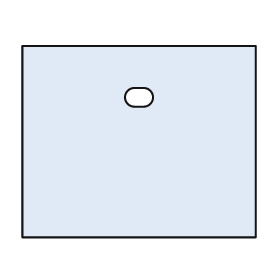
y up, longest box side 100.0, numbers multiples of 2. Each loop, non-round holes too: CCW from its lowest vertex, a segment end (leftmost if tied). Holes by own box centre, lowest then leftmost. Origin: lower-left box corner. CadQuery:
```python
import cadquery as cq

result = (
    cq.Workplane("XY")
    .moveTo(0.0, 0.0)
    .lineTo(100.0, 0.0)
    .lineTo(100.0, 82.0)
    .lineTo(0.0, 82.0)
    .close()
    .moveTo(48.0, 56.0)
    .lineTo(52.0, 56.0)
    .threePointArc((56.0, 60.0), (52.0, 64.0))
    .lineTo(48.0, 64.0)
    .threePointArc((44.0, 60.0), (48.0, 56.0))
    .close()
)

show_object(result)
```